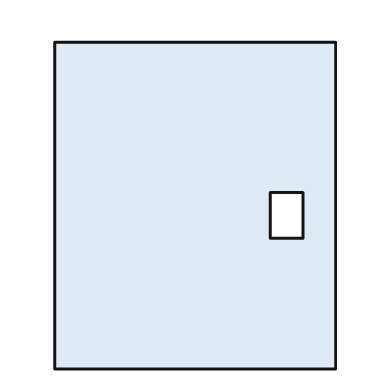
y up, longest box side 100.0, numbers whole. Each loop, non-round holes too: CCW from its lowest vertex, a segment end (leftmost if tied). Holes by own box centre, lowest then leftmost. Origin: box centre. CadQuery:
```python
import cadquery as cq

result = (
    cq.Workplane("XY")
    .moveTo(-43.0, -50.0)
    .lineTo(43.0, -50.0)
    .lineTo(43.0, 50.0)
    .lineTo(-43.0, 50.0)
    .close()
    .moveTo(23.0, -10.0)
    .lineTo(33.0, -10.0)
    .lineTo(33.0, 4.0)
    .lineTo(23.0, 4.0)
    .close()
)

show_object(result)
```